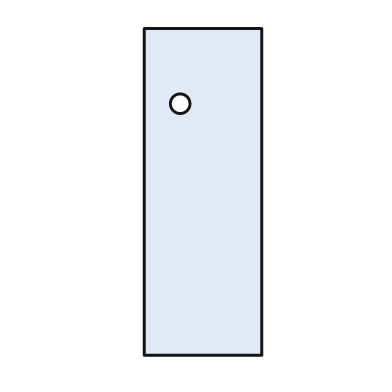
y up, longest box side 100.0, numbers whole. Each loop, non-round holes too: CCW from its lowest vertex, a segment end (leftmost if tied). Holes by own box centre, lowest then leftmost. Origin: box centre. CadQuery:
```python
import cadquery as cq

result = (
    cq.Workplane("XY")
    .moveTo(-18.0, -50.0)
    .lineTo(18.0, -50.0)
    .lineTo(18.0, 50.0)
    .lineTo(-18.0, 50.0)
    .close()
    .moveTo(-7.0, 27.0)
    .circle(3.0)
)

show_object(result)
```